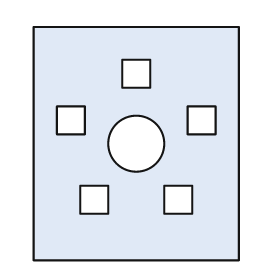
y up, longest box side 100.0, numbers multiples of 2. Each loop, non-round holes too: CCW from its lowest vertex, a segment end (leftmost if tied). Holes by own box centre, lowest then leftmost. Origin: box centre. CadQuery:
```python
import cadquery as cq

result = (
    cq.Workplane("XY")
    .moveTo(-44.0, -50.0)
    .lineTo(44.0, -50.0)
    .lineTo(44.0, 50.0)
    .lineTo(-44.0, 50.0)
    .close()
    .moveTo(-24.0, -30.0)
    .lineTo(-12.0, -30.0)
    .lineTo(-12.0, -18.0)
    .lineTo(-24.0, -18.0)
    .close()
    .moveTo(12.0, -30.0)
    .lineTo(24.0, -30.0)
    .lineTo(24.0, -18.0)
    .lineTo(12.0, -18.0)
    .close()
    .moveTo(0.0, 0.0)
    .circle(12.0)
    .moveTo(-34.0, 4.0)
    .lineTo(-22.0, 4.0)
    .lineTo(-22.0, 16.0)
    .lineTo(-34.0, 16.0)
    .close()
    .moveTo(22.0, 4.0)
    .lineTo(34.0, 4.0)
    .lineTo(34.0, 16.0)
    .lineTo(22.0, 16.0)
    .close()
    .moveTo(-6.0, 24.0)
    .lineTo(6.0, 24.0)
    .lineTo(6.0, 36.0)
    .lineTo(-6.0, 36.0)
    .close()
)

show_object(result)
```